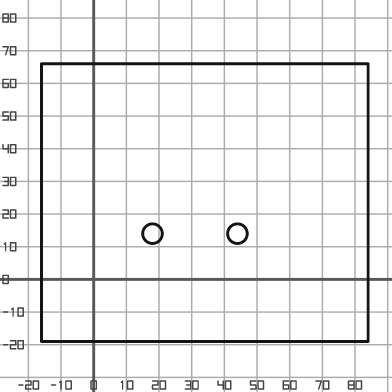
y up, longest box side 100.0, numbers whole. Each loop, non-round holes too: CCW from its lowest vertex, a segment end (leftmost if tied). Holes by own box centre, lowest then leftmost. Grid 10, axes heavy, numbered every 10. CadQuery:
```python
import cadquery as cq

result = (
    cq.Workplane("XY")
    .moveTo(-16.0, -19.0)
    .lineTo(84.0, -19.0)
    .lineTo(84.0, 66.0)
    .lineTo(-16.0, 66.0)
    .close()
    .moveTo(18.0, 14.0)
    .circle(3.0)
    .moveTo(44.0, 14.0)
    .circle(3.0)
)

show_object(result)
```